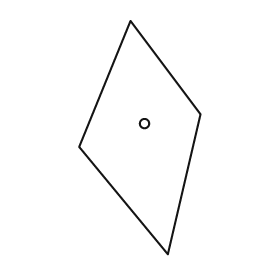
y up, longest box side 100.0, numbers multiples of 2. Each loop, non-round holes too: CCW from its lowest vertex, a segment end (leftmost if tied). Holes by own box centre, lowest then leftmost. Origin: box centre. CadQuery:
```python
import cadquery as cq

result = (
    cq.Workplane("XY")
    .moveTo(12.0, -50.0)
    .lineTo(26.0, 10.0)
    .lineTo(-4.0, 50.0)
    .lineTo(-26.0, -4.0)
    .close()
    .moveTo(2.0, 6.0)
    .circle(2.0)
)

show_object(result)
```